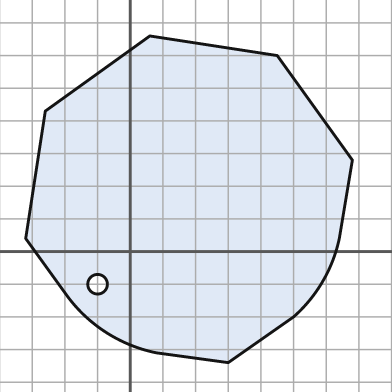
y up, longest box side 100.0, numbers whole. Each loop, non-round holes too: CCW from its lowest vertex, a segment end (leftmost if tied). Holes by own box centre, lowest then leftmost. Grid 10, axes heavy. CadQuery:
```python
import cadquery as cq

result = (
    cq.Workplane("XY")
    .moveTo(30.0, -34.0)
    .lineTo(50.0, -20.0)
    .threePointArc((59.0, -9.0), (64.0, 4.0))
    .lineTo(68.0, 28.0)
    .lineTo(45.0, 60.0)
    .lineTo(6.0, 66.0)
    .lineTo(-26.0, 43.0)
    .lineTo(-32.0, 4.0)
    .lineTo(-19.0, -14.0)
    .threePointArc((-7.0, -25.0), (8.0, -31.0))
    .close()
    .moveTo(-10.0, -10.0)
    .circle(3.0)
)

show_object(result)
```